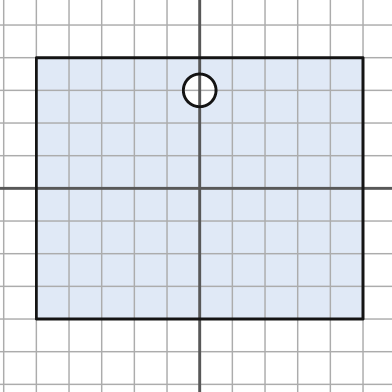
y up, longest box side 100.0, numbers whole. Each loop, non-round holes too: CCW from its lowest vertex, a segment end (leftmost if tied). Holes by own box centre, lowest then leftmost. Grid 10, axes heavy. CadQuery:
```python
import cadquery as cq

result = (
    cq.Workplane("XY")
    .moveTo(-50.0, -40.0)
    .lineTo(50.0, -40.0)
    .lineTo(50.0, 40.0)
    .lineTo(-50.0, 40.0)
    .close()
    .moveTo(0.0, 30.0)
    .circle(5.0)
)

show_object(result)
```